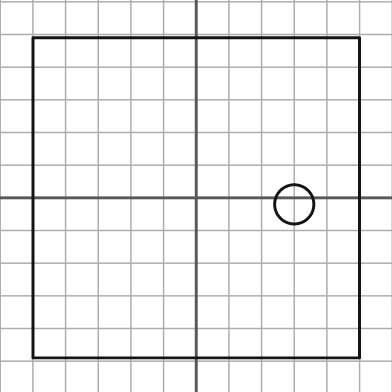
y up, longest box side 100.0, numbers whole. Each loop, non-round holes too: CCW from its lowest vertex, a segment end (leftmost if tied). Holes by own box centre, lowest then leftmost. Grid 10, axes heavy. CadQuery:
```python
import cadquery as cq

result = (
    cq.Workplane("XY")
    .moveTo(-50.0, -49.0)
    .lineTo(50.0, -49.0)
    .lineTo(50.0, 49.0)
    .lineTo(-50.0, 49.0)
    .close()
    .moveTo(30.0, -2.0)
    .circle(6.0)
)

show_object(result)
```